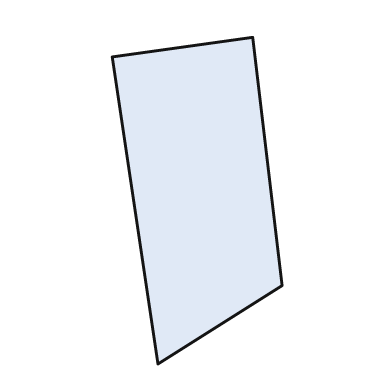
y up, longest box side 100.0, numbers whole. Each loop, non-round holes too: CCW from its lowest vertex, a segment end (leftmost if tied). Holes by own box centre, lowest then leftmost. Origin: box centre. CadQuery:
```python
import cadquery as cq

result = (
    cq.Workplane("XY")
    .moveTo(-12.0, -50.0)
    .lineTo(26.0, -26.0)
    .lineTo(17.0, 50.0)
    .lineTo(-26.0, 44.0)
    .close()
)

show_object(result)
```